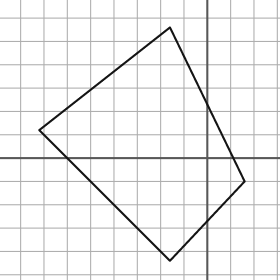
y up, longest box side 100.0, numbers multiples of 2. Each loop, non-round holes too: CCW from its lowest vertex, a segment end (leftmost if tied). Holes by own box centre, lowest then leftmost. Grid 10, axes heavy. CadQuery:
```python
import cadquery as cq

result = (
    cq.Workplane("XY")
    .moveTo(-16.0, -44.0)
    .lineTo(16.0, -10.0)
    .lineTo(-16.0, 56.0)
    .lineTo(-72.0, 12.0)
    .close()
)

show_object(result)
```